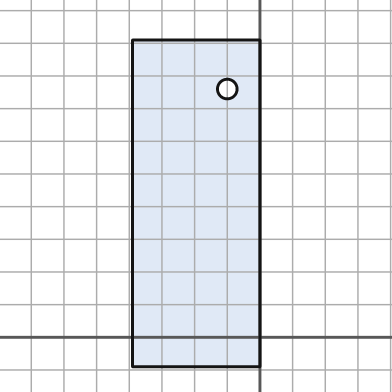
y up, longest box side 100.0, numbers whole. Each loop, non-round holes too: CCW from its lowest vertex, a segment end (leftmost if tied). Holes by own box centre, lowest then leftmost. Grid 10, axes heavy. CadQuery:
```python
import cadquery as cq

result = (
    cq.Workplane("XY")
    .moveTo(-39.0, -9.0)
    .lineTo(0.0, -9.0)
    .lineTo(0.0, 91.0)
    .lineTo(-39.0, 91.0)
    .close()
    .moveTo(-10.0, 76.0)
    .circle(3.0)
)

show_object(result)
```